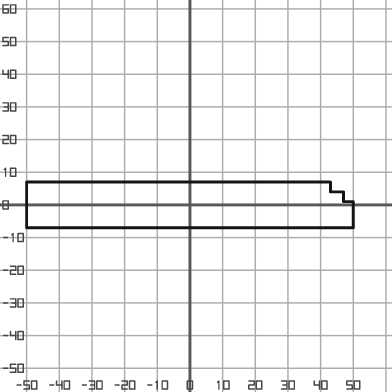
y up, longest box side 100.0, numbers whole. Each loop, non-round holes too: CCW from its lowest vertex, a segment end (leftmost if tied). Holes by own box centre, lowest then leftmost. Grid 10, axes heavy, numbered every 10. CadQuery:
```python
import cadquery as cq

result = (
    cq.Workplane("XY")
    .moveTo(-50.0, -7.0)
    .lineTo(50.0, -7.0)
    .lineTo(50.0, 1.0)
    .lineTo(47.0, 1.0)
    .lineTo(47.0, 4.0)
    .lineTo(43.0, 4.0)
    .lineTo(43.0, 7.0)
    .lineTo(-50.0, 7.0)
    .close()
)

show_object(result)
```